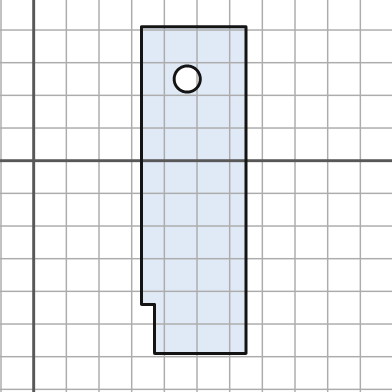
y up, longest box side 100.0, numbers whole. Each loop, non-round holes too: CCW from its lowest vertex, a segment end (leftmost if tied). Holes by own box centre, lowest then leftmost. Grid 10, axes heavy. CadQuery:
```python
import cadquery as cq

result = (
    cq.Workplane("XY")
    .moveTo(37.0, -59.0)
    .lineTo(65.0, -59.0)
    .lineTo(65.0, 41.0)
    .lineTo(33.0, 41.0)
    .lineTo(33.0, -44.0)
    .lineTo(37.0, -44.0)
    .close()
    .moveTo(47.0, 25.0)
    .circle(4.0)
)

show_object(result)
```